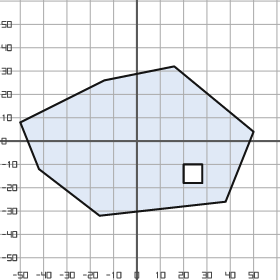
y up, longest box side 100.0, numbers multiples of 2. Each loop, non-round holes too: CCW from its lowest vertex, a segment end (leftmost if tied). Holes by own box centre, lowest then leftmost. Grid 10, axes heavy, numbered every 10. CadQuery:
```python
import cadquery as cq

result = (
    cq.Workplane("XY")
    .moveTo(-16.0, -32.0)
    .lineTo(38.0, -26.0)
    .lineTo(50.0, 4.0)
    .lineTo(16.0, 32.0)
    .lineTo(-14.0, 26.0)
    .lineTo(-50.0, 8.0)
    .lineTo(-42.0, -12.0)
    .close()
    .moveTo(20.0, -18.0)
    .lineTo(28.0, -18.0)
    .lineTo(28.0, -10.0)
    .lineTo(20.0, -10.0)
    .close()
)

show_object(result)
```